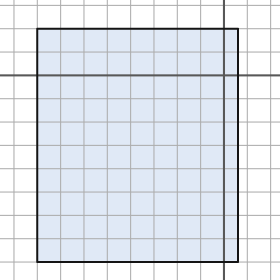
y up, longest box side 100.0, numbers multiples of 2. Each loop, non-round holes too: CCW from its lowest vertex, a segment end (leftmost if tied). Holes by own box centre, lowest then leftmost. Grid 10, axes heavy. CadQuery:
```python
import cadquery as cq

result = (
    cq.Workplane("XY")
    .moveTo(-80.0, -80.0)
    .lineTo(6.0, -80.0)
    .lineTo(6.0, 20.0)
    .lineTo(-80.0, 20.0)
    .close()
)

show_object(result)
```